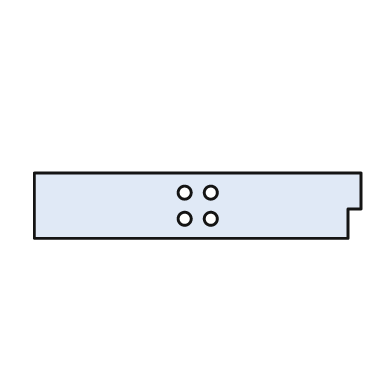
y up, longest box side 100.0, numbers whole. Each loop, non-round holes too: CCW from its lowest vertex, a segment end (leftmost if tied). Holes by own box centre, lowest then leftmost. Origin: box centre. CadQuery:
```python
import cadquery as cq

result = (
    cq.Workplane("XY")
    .moveTo(-50.0, -10.0)
    .lineTo(46.0, -10.0)
    .lineTo(46.0, -1.0)
    .lineTo(50.0, -1.0)
    .lineTo(50.0, 10.0)
    .lineTo(-50.0, 10.0)
    .close()
    .moveTo(-4.0, -4.0)
    .circle(2.0)
    .moveTo(4.0, -4.0)
    .circle(2.0)
    .moveTo(-4.0, 4.0)
    .circle(2.0)
    .moveTo(4.0, 4.0)
    .circle(2.0)
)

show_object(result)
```